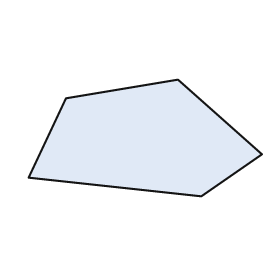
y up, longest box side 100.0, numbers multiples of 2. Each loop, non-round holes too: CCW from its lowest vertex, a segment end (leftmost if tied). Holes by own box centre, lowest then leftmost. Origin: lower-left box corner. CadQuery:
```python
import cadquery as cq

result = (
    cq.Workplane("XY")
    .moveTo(74.0, 0.0)
    .lineTo(100.0, 18.0)
    .lineTo(64.0, 50.0)
    .lineTo(16.0, 42.0)
    .lineTo(0.0, 8.0)
    .close()
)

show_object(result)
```